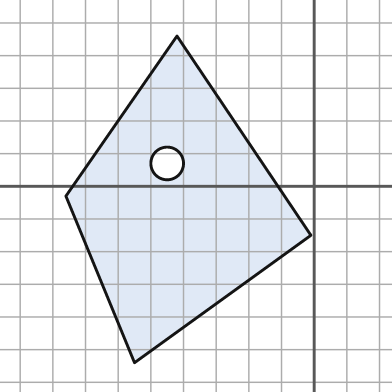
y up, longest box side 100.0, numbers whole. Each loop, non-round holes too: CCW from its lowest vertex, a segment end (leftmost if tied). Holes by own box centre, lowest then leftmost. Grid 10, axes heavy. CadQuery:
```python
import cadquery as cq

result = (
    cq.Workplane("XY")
    .moveTo(-55.0, -54.0)
    .lineTo(-1.0, -15.0)
    .lineTo(-42.0, 46.0)
    .lineTo(-76.0, -3.0)
    .close()
    .moveTo(-45.0, 7.0)
    .circle(5.0)
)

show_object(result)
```